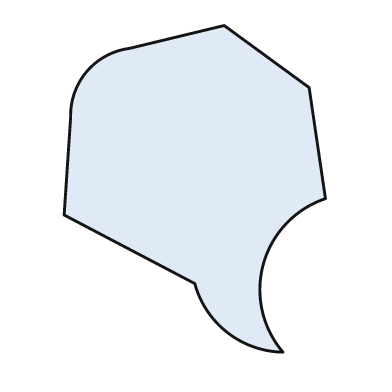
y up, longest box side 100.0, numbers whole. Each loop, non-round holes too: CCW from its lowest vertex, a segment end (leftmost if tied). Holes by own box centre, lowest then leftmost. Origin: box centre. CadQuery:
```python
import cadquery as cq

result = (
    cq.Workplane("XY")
    .moveTo(27.0, -50.0)
    .threePointArc((21.0, -23.0), (40.0, -3.0))
    .lineTo(35.0, 31.0)
    .lineTo(9.0, 50.0)
    .lineTo(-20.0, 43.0)
    .threePointArc((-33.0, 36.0), (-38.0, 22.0))
    .lineTo(-40.0, -8.0)
    .lineTo(0.0, -29.0)
    .threePointArc((10.0, -44.0), (27.0, -50.0))
    .close()
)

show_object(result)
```